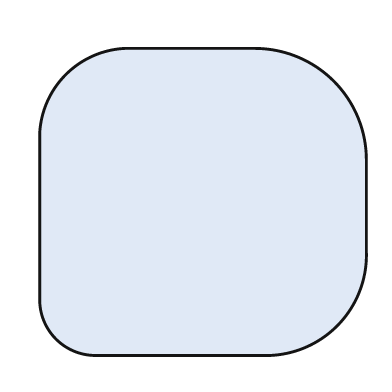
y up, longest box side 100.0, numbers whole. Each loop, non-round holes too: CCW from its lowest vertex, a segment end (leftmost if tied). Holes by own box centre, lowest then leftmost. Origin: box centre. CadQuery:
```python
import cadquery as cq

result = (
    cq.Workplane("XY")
    .moveTo(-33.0, -47.0)
    .lineTo(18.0, -47.0)
    .threePointArc((41.0, -38.0), (50.0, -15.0))
    .lineTo(50.0, 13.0)
    .threePointArc((40.0, 37.0), (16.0, 47.0))
    .lineTo(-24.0, 47.0)
    .threePointArc((-42.0, 39.0), (-50.0, 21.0))
    .lineTo(-50.0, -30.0)
    .threePointArc((-45.0, -42.0), (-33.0, -47.0))
    .close()
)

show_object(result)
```